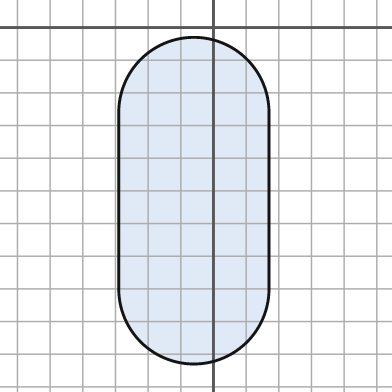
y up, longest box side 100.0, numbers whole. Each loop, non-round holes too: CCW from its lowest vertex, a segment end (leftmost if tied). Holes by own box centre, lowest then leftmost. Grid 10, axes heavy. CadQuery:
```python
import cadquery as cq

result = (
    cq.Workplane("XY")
    .moveTo(-29.0, -80.0)
    .threePointArc((-6.0, -103.0), (17.0, -80.0))
    .lineTo(17.0, -26.0)
    .threePointArc((-6.0, -3.0), (-29.0, -26.0))
    .close()
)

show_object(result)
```